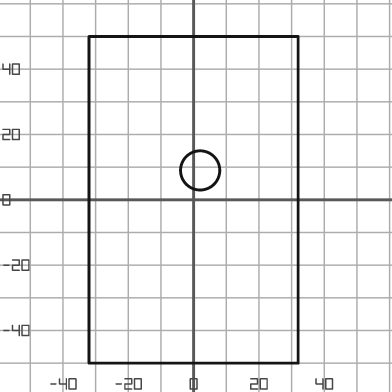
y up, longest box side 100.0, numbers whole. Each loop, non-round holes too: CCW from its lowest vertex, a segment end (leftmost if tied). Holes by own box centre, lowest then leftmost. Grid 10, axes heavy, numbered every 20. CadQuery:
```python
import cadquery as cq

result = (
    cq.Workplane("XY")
    .moveTo(-32.0, -50.0)
    .lineTo(32.0, -50.0)
    .lineTo(32.0, 50.0)
    .lineTo(-32.0, 50.0)
    .close()
    .moveTo(2.0, 9.0)
    .circle(6.0)
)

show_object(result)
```